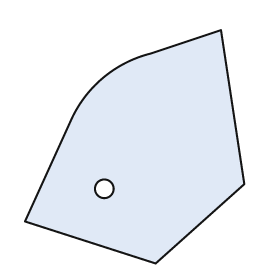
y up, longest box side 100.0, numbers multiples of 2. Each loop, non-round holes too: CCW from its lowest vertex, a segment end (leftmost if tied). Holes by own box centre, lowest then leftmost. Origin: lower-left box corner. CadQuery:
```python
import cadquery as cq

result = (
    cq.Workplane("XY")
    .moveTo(56.0, 0.0)
    .lineTo(94.0, 34.0)
    .lineTo(84.0, 100.0)
    .lineTo(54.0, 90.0)
    .threePointArc((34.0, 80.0), (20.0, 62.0))
    .lineTo(0.0, 18.0)
    .close()
    .moveTo(34.0, 32.0)
    .circle(4.0)
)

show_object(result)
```